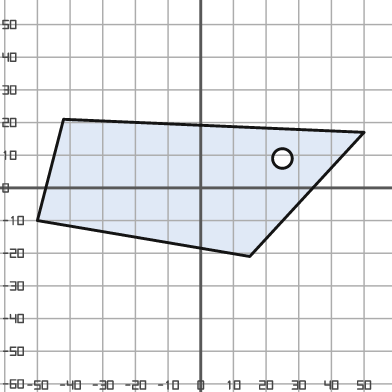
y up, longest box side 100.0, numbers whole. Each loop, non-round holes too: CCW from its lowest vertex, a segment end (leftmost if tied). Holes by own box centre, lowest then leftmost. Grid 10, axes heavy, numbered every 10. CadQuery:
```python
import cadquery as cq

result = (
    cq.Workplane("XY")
    .moveTo(15.0, -21.0)
    .lineTo(50.0, 17.0)
    .lineTo(-42.0, 21.0)
    .lineTo(-50.0, -10.0)
    .close()
    .moveTo(25.0, 9.0)
    .circle(3.0)
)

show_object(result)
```